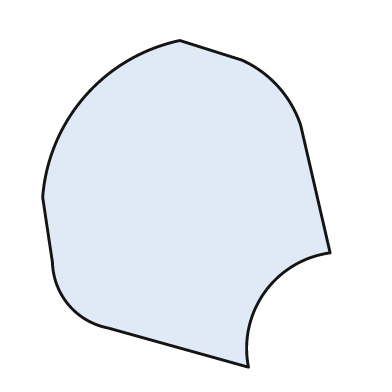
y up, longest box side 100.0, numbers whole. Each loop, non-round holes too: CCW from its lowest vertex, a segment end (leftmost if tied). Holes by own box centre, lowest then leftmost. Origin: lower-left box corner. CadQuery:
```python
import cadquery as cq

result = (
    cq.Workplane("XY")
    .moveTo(63.0, 0.0)
    .threePointArc((68.0, 23.0), (88.0, 35.0))
    .lineTo(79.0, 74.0)
    .threePointArc((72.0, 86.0), (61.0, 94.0))
    .lineTo(42.0, 100.0)
    .threePointArc((13.0, 83.0), (0.0, 52.0))
    .lineTo(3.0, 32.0)
    .threePointArc((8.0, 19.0), (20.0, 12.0))
    .close()
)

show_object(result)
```